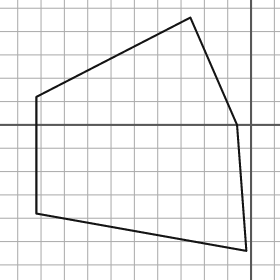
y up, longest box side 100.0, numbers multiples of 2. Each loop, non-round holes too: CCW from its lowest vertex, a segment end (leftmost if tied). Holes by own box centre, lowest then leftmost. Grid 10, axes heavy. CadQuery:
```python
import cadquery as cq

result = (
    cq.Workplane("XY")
    .moveTo(-2.0, -54.0)
    .lineTo(-6.0, 0.0)
    .lineTo(-26.0, 46.0)
    .lineTo(-92.0, 12.0)
    .lineTo(-92.0, -38.0)
    .close()
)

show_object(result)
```